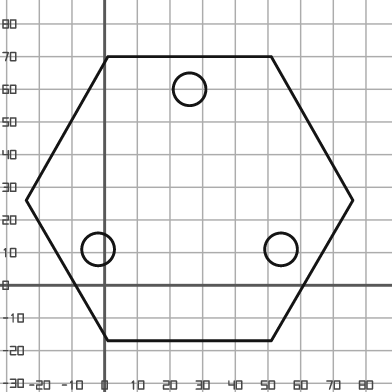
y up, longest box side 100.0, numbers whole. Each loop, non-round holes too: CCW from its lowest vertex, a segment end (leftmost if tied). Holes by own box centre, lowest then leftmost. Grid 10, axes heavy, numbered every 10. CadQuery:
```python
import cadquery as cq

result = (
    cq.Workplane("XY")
    .moveTo(1.0, -17.0)
    .lineTo(51.0, -17.0)
    .lineTo(76.0, 26.0)
    .lineTo(51.0, 70.0)
    .lineTo(1.0, 70.0)
    .lineTo(-24.0, 26.0)
    .close()
    .moveTo(-2.0, 11.0)
    .circle(5.0)
    .moveTo(54.0, 11.0)
    .circle(5.0)
    .moveTo(26.0, 60.0)
    .circle(5.0)
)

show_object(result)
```